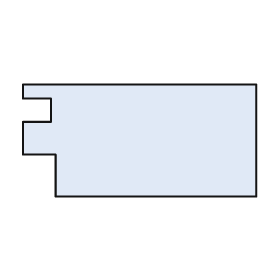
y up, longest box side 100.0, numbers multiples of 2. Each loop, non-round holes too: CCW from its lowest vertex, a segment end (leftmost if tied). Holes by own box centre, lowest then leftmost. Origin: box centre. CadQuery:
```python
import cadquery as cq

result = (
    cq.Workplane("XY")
    .moveTo(-36.0, -24.0)
    .lineTo(50.0, -24.0)
    .lineTo(50.0, 24.0)
    .lineTo(-50.0, 24.0)
    .lineTo(-50.0, 18.0)
    .lineTo(-38.0, 18.0)
    .lineTo(-38.0, 8.0)
    .lineTo(-50.0, 8.0)
    .lineTo(-50.0, -6.0)
    .lineTo(-36.0, -6.0)
    .close()
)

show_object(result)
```